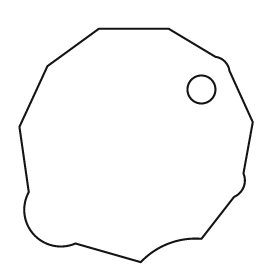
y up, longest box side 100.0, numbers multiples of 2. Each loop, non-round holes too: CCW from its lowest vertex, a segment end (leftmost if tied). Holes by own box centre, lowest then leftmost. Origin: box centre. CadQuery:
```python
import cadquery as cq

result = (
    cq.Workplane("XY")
    .moveTo(2.0, -50.0)
    .threePointArc((14.0, -42.0), (28.0, -40.0))
    .lineTo(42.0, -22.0)
    .threePointArc((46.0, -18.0), (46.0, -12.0))
    .lineTo(50.0, 10.0)
    .lineTo(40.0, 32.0)
    .threePointArc((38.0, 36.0), (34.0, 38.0))
    .lineTo(14.0, 50.0)
    .lineTo(-16.0, 50.0)
    .lineTo(-38.0, 34.0)
    .lineTo(-50.0, 8.0)
    .lineTo(-46.0, -20.0)
    .threePointArc((-44.0, -38.0), (-26.0, -42.0))
    .close()
    .moveTo(28.0, 24.0)
    .circle(6.0)
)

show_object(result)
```